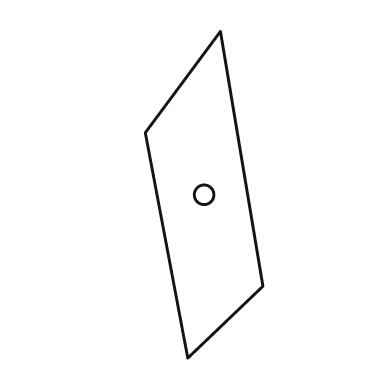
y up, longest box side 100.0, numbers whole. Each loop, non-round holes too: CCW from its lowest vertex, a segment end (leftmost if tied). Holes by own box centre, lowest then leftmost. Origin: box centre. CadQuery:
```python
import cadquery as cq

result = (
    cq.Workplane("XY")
    .moveTo(-5.0, -50.0)
    .lineTo(18.0, -28.0)
    .lineTo(5.0, 50.0)
    .lineTo(-18.0, 19.0)
    .close()
    .moveTo(0.0, 0.0)
    .circle(3.0)
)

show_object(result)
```